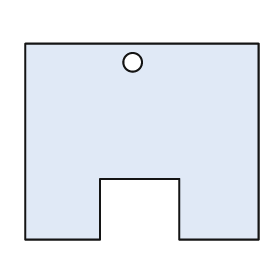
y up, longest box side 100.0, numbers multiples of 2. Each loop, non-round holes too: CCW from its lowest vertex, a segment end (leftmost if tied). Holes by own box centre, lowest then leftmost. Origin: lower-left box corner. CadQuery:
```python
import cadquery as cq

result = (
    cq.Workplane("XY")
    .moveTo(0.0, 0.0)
    .lineTo(32.0, 0.0)
    .lineTo(32.0, 26.0)
    .lineTo(66.0, 26.0)
    .lineTo(66.0, 0.0)
    .lineTo(100.0, 0.0)
    .lineTo(100.0, 84.0)
    .lineTo(0.0, 84.0)
    .close()
    .moveTo(46.0, 76.0)
    .circle(4.0)
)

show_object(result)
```